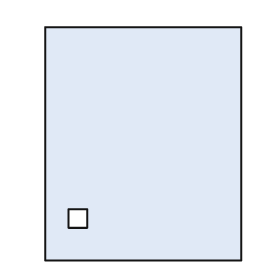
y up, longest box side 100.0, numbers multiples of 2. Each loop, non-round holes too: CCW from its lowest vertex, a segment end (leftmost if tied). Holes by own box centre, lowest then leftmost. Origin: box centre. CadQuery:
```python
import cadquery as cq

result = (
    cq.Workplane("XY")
    .moveTo(-42.0, -50.0)
    .lineTo(42.0, -50.0)
    .lineTo(42.0, 50.0)
    .lineTo(-42.0, 50.0)
    .close()
    .moveTo(-32.0, -36.0)
    .lineTo(-24.0, -36.0)
    .lineTo(-24.0, -28.0)
    .lineTo(-32.0, -28.0)
    .close()
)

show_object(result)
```